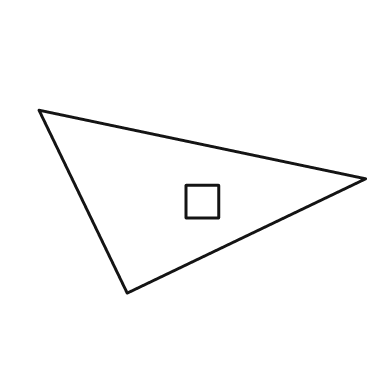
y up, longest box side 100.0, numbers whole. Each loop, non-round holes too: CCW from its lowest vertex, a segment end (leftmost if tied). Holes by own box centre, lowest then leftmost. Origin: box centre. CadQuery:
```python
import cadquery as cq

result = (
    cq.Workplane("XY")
    .moveTo(-23.0, -28.0)
    .lineTo(50.0, 7.0)
    .lineTo(-50.0, 28.0)
    .close()
    .moveTo(-5.0, -5.0)
    .lineTo(5.0, -5.0)
    .lineTo(5.0, 5.0)
    .lineTo(-5.0, 5.0)
    .close()
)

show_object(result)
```